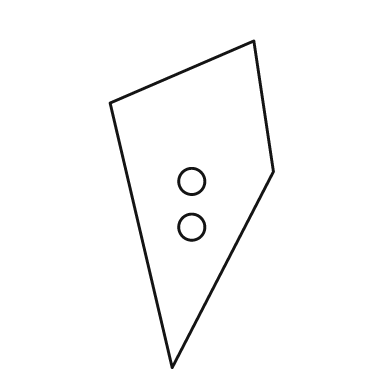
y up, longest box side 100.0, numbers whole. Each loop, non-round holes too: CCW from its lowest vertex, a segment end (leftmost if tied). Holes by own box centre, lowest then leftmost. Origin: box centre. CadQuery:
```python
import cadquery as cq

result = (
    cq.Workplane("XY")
    .moveTo(-6.0, -50.0)
    .lineTo(25.0, 10.0)
    .lineTo(19.0, 50.0)
    .lineTo(-25.0, 31.0)
    .close()
    .moveTo(0.0, -7.0)
    .circle(4.0)
    .moveTo(0.0, 7.0)
    .circle(4.0)
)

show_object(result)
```